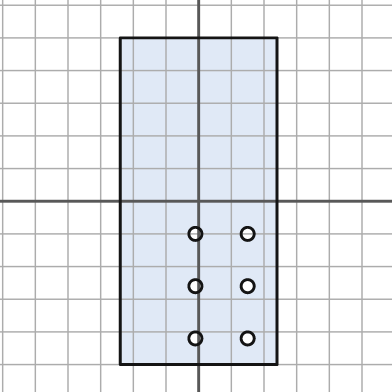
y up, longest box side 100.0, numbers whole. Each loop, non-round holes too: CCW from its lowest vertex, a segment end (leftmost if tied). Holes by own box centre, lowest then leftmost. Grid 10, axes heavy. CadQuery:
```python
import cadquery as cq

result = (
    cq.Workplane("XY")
    .moveTo(-24.0, -50.0)
    .lineTo(24.0, -50.0)
    .lineTo(24.0, 50.0)
    .lineTo(-24.0, 50.0)
    .close()
    .moveTo(-1.0, -42.0)
    .circle(2.0)
    .moveTo(15.0, -42.0)
    .circle(2.0)
    .moveTo(-1.0, -26.0)
    .circle(2.0)
    .moveTo(15.0, -26.0)
    .circle(2.0)
    .moveTo(-1.0, -10.0)
    .circle(2.0)
    .moveTo(15.0, -10.0)
    .circle(2.0)
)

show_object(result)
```